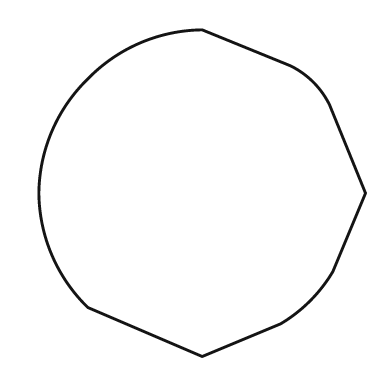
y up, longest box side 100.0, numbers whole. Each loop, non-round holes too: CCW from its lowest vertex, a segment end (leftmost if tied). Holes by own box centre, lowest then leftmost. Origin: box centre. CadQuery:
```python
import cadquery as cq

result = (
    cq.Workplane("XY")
    .moveTo(0.0, -50.0)
    .lineTo(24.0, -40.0)
    .threePointArc((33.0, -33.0), (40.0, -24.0))
    .lineTo(50.0, 0.0)
    .lineTo(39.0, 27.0)
    .threePointArc((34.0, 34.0), (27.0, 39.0))
    .lineTo(0.0, 50.0)
    .threePointArc((-19.0, 46.0), (-35.0, 35.0))
    .threePointArc((-46.0, 19.0), (-50.0, 0.0))
    .threePointArc((-46.0, -19.0), (-35.0, -35.0))
    .close()
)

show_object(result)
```